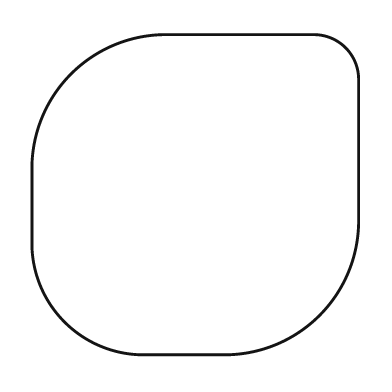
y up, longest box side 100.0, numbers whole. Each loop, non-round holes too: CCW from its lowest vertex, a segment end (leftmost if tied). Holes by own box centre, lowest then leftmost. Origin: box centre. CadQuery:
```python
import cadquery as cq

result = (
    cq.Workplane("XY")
    .moveTo(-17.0, -49.0)
    .lineTo(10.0, -49.0)
    .threePointArc((38.0, -37.0), (50.0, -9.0))
    .lineTo(50.0, 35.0)
    .threePointArc((46.0, 45.0), (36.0, 49.0))
    .lineTo(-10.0, 49.0)
    .threePointArc((-38.0, 37.0), (-50.0, 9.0))
    .lineTo(-50.0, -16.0)
    .threePointArc((-40.0, -39.0), (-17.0, -49.0))
    .close()
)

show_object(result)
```